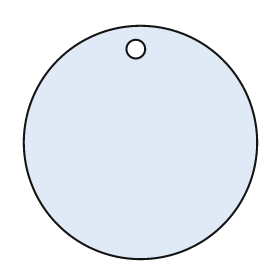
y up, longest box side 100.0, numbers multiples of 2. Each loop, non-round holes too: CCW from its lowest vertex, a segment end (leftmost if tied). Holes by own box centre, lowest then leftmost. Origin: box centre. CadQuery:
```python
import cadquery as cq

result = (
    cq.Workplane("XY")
    .moveTo(0.0, 0.0)
    .circle(50.0)
    .moveTo(-2.0, 40.0)
    .circle(4.0)
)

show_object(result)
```